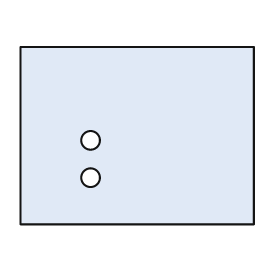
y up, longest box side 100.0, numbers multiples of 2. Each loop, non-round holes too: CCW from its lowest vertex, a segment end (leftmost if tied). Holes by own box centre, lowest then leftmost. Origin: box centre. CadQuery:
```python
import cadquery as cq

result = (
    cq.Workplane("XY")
    .moveTo(-50.0, -38.0)
    .lineTo(50.0, -38.0)
    .lineTo(50.0, 38.0)
    .lineTo(-50.0, 38.0)
    .close()
    .moveTo(-20.0, -18.0)
    .circle(4.0)
    .moveTo(-20.0, -2.0)
    .circle(4.0)
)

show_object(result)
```